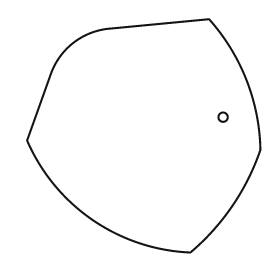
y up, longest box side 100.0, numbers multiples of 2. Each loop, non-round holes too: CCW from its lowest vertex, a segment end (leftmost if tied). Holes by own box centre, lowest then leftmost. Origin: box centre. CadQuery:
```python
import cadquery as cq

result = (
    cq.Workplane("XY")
    .moveTo(20.0, -50.0)
    .threePointArc((38.0, -30.0), (50.0, -6.0))
    .threePointArc((44.0, 24.0), (28.0, 50.0))
    .lineTo(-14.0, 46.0)
    .threePointArc((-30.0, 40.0), (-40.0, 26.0))
    .lineTo(-50.0, -2.0)
    .threePointArc((-22.0, -36.0), (20.0, -50.0))
    .close()
    .moveTo(34.0, 8.0)
    .circle(2.0)
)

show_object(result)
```